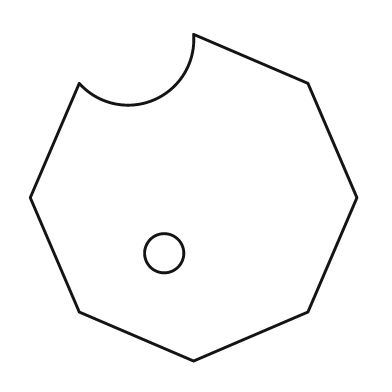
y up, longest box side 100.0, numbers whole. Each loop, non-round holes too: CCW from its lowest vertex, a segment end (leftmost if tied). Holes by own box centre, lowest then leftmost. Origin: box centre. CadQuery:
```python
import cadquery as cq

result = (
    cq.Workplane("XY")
    .moveTo(0.0, -50.0)
    .lineTo(35.0, -35.0)
    .lineTo(50.0, 0.0)
    .lineTo(35.0, 35.0)
    .lineTo(0.0, 50.0)
    .threePointArc((-12.0, 30.0), (-35.0, 35.0))
    .lineTo(-50.0, 0.0)
    .lineTo(-35.0, -35.0)
    .close()
    .moveTo(-9.0, -17.0)
    .circle(6.0)
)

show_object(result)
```